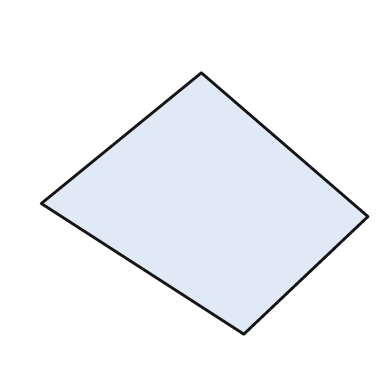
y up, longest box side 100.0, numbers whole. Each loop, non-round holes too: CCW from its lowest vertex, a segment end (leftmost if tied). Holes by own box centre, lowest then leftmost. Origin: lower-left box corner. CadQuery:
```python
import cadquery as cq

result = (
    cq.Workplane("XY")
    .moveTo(62.0, 0.0)
    .lineTo(100.0, 36.0)
    .lineTo(49.0, 80.0)
    .lineTo(0.0, 40.0)
    .close()
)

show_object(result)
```